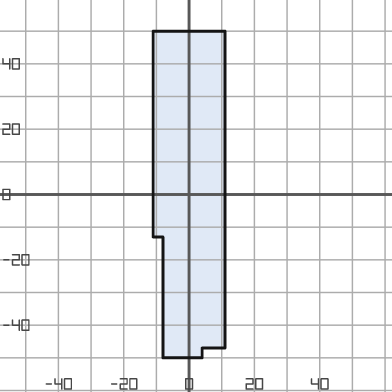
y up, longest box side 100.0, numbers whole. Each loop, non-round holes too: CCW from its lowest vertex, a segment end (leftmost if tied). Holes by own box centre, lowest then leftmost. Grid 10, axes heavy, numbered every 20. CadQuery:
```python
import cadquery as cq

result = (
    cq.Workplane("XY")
    .moveTo(-8.0, -50.0)
    .lineTo(4.0, -50.0)
    .lineTo(4.0, -47.0)
    .lineTo(11.0, -47.0)
    .lineTo(11.0, 50.0)
    .lineTo(-11.0, 50.0)
    .lineTo(-11.0, -13.0)
    .lineTo(-8.0, -13.0)
    .close()
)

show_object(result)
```